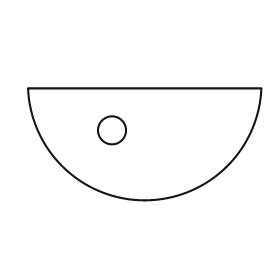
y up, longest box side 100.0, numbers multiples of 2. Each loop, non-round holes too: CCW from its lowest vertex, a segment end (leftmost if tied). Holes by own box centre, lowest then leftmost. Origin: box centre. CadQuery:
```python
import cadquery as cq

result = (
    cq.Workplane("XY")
    .moveTo(-50.0, 24.0)
    .threePointArc((0.0, -24.0), (50.0, 24.0))
    .close()
    .moveTo(-14.0, 6.0)
    .circle(6.0)
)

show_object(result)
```